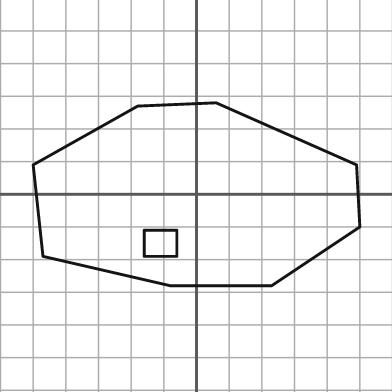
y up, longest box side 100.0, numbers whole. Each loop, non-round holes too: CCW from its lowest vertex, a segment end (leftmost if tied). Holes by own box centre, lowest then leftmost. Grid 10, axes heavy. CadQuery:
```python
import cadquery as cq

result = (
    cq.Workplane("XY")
    .moveTo(-8.0, -28.0)
    .lineTo(23.0, -28.0)
    .lineTo(50.0, -10.0)
    .lineTo(49.0, 9.0)
    .lineTo(6.0, 28.0)
    .lineTo(-18.0, 27.0)
    .lineTo(-50.0, 9.0)
    .lineTo(-47.0, -19.0)
    .close()
    .moveTo(-16.0, -19.0)
    .lineTo(-6.0, -19.0)
    .lineTo(-6.0, -11.0)
    .lineTo(-16.0, -11.0)
    .close()
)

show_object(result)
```